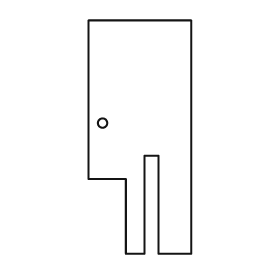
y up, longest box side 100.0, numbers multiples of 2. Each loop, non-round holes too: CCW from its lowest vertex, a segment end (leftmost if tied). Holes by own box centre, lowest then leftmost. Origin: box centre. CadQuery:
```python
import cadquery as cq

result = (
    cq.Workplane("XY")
    .moveTo(-6.0, -50.0)
    .lineTo(2.0, -50.0)
    .lineTo(2.0, -8.0)
    .lineTo(8.0, -8.0)
    .lineTo(8.0, -50.0)
    .lineTo(22.0, -50.0)
    .lineTo(22.0, 50.0)
    .lineTo(-22.0, 50.0)
    .lineTo(-22.0, -18.0)
    .lineTo(-6.0, -18.0)
    .close()
    .moveTo(-16.0, 6.0)
    .circle(2.0)
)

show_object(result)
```